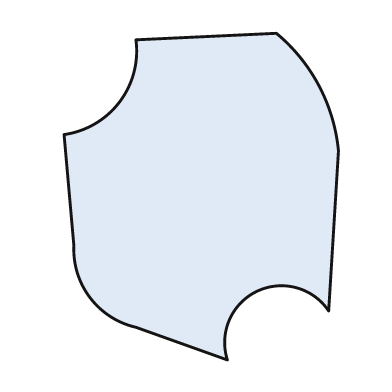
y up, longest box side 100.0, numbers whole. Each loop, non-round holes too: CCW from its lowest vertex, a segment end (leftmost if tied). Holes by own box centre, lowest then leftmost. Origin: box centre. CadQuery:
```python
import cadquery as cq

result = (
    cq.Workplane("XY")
    .moveTo(8.0, -50.0)
    .threePointArc((17.0, -29.0), (39.0, -35.0))
    .lineTo(42.0, 14.0)
    .threePointArc((36.0, 34.0), (23.0, 50.0))
    .lineTo(-20.0, 48.0)
    .threePointArc((-25.0, 29.0), (-42.0, 19.0))
    .lineTo(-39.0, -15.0)
    .threePointArc((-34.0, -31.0), (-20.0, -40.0))
    .close()
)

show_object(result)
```